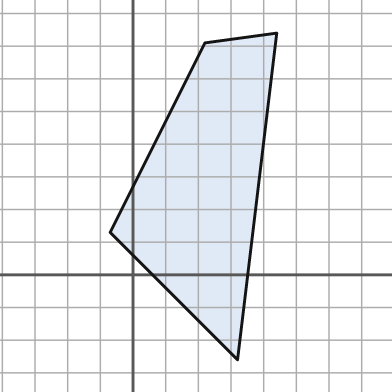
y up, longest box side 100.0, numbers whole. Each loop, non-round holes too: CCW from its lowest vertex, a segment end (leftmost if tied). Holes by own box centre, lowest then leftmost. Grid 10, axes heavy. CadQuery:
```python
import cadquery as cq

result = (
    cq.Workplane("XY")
    .moveTo(32.0, -26.0)
    .lineTo(44.0, 74.0)
    .lineTo(22.0, 71.0)
    .lineTo(-7.0, 13.0)
    .close()
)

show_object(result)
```